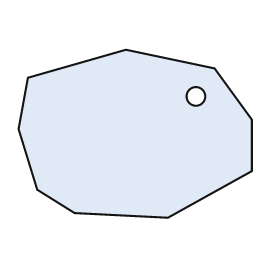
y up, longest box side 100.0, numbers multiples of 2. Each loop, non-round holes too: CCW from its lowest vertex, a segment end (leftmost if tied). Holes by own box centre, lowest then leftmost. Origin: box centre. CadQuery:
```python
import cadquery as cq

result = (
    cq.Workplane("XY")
    .moveTo(14.0, -36.0)
    .lineTo(50.0, -16.0)
    .lineTo(50.0, 6.0)
    .lineTo(34.0, 28.0)
    .lineTo(-4.0, 36.0)
    .lineTo(-46.0, 24.0)
    .lineTo(-50.0, 2.0)
    .lineTo(-42.0, -24.0)
    .lineTo(-26.0, -34.0)
    .close()
    .moveTo(26.0, 16.0)
    .circle(4.0)
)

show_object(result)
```